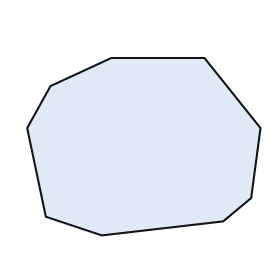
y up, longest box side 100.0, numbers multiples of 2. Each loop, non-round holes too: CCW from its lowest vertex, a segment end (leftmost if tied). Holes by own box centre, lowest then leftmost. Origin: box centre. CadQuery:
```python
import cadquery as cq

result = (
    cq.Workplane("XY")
    .moveTo(-18.0, -38.0)
    .lineTo(34.0, -32.0)
    .lineTo(46.0, -22.0)
    .lineTo(50.0, 8.0)
    .lineTo(26.0, 38.0)
    .lineTo(-14.0, 38.0)
    .lineTo(-40.0, 26.0)
    .lineTo(-50.0, 8.0)
    .lineTo(-42.0, -30.0)
    .close()
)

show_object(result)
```